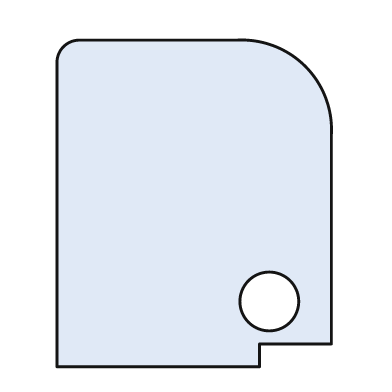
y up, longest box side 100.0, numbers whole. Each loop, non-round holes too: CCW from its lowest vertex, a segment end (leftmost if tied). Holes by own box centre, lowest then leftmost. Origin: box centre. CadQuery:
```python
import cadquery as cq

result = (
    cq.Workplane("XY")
    .moveTo(-42.0, -50.0)
    .lineTo(20.0, -50.0)
    .lineTo(20.0, -43.0)
    .lineTo(42.0, -43.0)
    .lineTo(42.0, 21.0)
    .threePointArc((34.0, 42.0), (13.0, 50.0))
    .lineTo(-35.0, 50.0)
    .threePointArc((-40.0, 48.0), (-42.0, 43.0))
    .close()
    .moveTo(23.0, -30.0)
    .circle(9.0)
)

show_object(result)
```